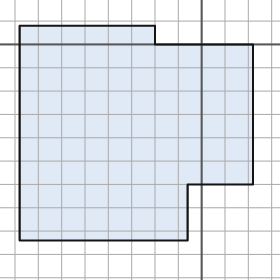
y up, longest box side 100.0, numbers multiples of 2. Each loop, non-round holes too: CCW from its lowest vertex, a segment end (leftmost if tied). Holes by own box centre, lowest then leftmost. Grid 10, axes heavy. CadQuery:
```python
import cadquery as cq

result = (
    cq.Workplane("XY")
    .moveTo(-78.0, -84.0)
    .lineTo(-6.0, -84.0)
    .lineTo(-6.0, -60.0)
    .lineTo(22.0, -60.0)
    .lineTo(22.0, 0.0)
    .lineTo(-20.0, 0.0)
    .lineTo(-20.0, 8.0)
    .lineTo(-78.0, 8.0)
    .close()
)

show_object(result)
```